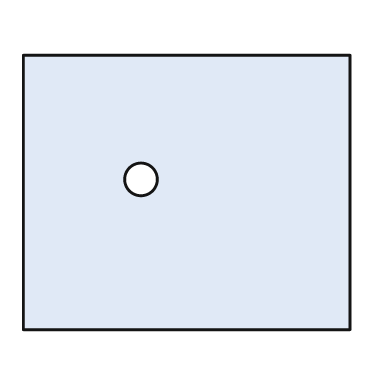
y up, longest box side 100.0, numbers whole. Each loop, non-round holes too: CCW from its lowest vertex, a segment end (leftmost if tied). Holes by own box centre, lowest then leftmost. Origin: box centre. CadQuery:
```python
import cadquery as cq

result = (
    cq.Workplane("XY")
    .moveTo(-50.0, -42.0)
    .lineTo(50.0, -42.0)
    .lineTo(50.0, 42.0)
    .lineTo(-50.0, 42.0)
    .close()
    .moveTo(-14.0, 4.0)
    .circle(5.0)
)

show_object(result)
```